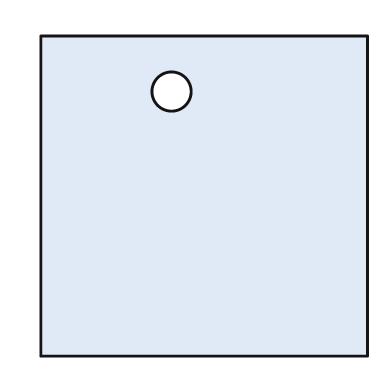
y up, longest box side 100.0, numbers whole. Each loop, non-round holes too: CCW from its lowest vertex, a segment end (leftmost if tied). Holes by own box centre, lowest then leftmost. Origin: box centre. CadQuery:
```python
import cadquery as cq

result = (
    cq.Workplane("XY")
    .moveTo(-50.0, -49.0)
    .lineTo(50.0, -49.0)
    .lineTo(50.0, 49.0)
    .lineTo(-50.0, 49.0)
    .close()
    .moveTo(-10.0, 32.0)
    .circle(6.0)
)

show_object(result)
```